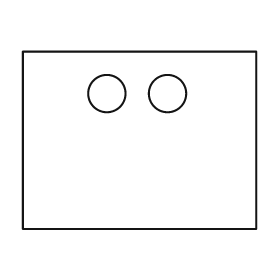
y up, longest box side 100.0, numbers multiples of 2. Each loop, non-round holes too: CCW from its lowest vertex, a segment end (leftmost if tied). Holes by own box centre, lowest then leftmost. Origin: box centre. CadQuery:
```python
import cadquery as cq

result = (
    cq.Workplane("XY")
    .moveTo(-50.0, -38.0)
    .lineTo(50.0, -38.0)
    .lineTo(50.0, 38.0)
    .lineTo(-50.0, 38.0)
    .close()
    .moveTo(-14.0, 20.0)
    .circle(8.0)
    .moveTo(12.0, 20.0)
    .circle(8.0)
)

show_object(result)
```